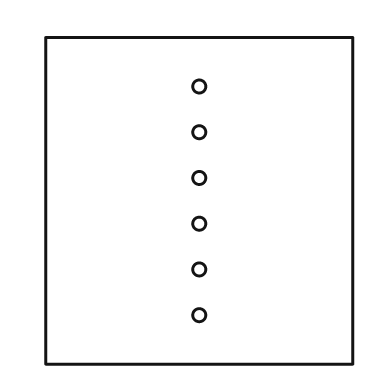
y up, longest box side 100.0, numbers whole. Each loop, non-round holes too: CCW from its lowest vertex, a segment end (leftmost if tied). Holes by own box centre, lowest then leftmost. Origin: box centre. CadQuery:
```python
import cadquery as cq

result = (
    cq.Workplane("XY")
    .moveTo(-47.0, -50.0)
    .lineTo(47.0, -50.0)
    .lineTo(47.0, 50.0)
    .lineTo(-47.0, 50.0)
    .close()
    .moveTo(0.0, -35.0)
    .circle(2.0)
    .moveTo(0.0, -21.0)
    .circle(2.0)
    .moveTo(0.0, -7.0)
    .circle(2.0)
    .moveTo(0.0, 7.0)
    .circle(2.0)
    .moveTo(0.0, 21.0)
    .circle(2.0)
    .moveTo(0.0, 35.0)
    .circle(2.0)
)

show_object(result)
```